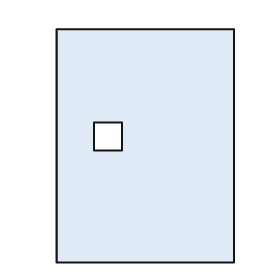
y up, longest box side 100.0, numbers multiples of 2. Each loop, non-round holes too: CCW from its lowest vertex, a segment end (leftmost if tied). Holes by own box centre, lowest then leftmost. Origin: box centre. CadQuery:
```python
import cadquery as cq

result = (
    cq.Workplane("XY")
    .moveTo(-38.0, -50.0)
    .lineTo(38.0, -50.0)
    .lineTo(38.0, 50.0)
    .lineTo(-38.0, 50.0)
    .close()
    .moveTo(-22.0, -2.0)
    .lineTo(-10.0, -2.0)
    .lineTo(-10.0, 10.0)
    .lineTo(-22.0, 10.0)
    .close()
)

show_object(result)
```